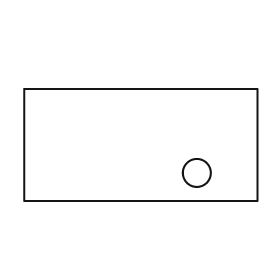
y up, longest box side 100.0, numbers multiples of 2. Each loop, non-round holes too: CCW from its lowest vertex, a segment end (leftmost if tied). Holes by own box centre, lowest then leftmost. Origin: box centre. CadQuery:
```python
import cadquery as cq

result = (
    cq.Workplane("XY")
    .moveTo(-50.0, -24.0)
    .lineTo(50.0, -24.0)
    .lineTo(50.0, 24.0)
    .lineTo(-50.0, 24.0)
    .close()
    .moveTo(24.0, -12.0)
    .circle(6.0)
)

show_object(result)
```